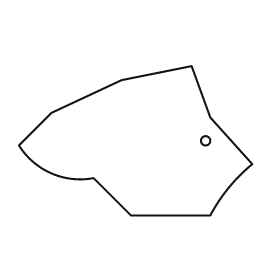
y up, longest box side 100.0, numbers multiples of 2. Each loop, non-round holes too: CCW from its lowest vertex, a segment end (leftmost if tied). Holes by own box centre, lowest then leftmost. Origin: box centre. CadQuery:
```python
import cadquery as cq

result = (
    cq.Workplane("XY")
    .moveTo(-2.0, -32.0)
    .lineTo(32.0, -32.0)
    .threePointArc((40.0, -20.0), (50.0, -10.0))
    .lineTo(32.0, 10.0)
    .lineTo(24.0, 32.0)
    .lineTo(-6.0, 26.0)
    .lineTo(-36.0, 12.0)
    .lineTo(-50.0, -2.0)
    .threePointArc((-36.0, -14.0), (-18.0, -16.0))
    .close()
    .moveTo(30.0, 0.0)
    .circle(2.0)
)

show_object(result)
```